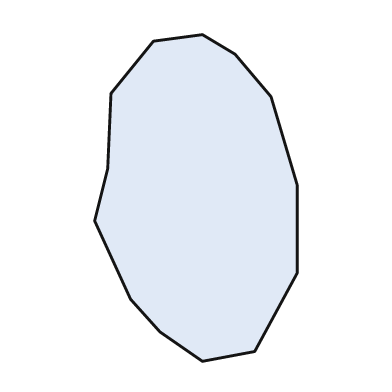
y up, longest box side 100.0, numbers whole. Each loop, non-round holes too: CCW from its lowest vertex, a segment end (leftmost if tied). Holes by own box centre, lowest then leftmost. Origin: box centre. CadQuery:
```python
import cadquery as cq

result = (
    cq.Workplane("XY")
    .moveTo(2.0, -50.0)
    .lineTo(18.0, -47.0)
    .lineTo(31.0, -23.0)
    .lineTo(31.0, 4.0)
    .lineTo(23.0, 31.0)
    .lineTo(12.0, 44.0)
    .lineTo(2.0, 50.0)
    .lineTo(-13.0, 48.0)
    .lineTo(-26.0, 32.0)
    .lineTo(-27.0, 9.0)
    .lineTo(-31.0, -7.0)
    .lineTo(-20.0, -31.0)
    .lineTo(-11.0, -41.0)
    .close()
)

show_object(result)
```